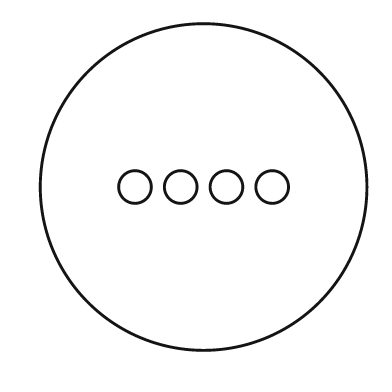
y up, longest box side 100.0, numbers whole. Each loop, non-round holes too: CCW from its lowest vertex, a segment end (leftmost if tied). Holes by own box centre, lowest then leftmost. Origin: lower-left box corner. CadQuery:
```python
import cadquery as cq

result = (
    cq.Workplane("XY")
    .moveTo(50.0, 50.0)
    .circle(50.0)
    .moveTo(29.0, 50.0)
    .circle(5.0)
    .moveTo(43.0, 50.0)
    .circle(5.0)
    .moveTo(57.0, 50.0)
    .circle(5.0)
    .moveTo(71.0, 50.0)
    .circle(5.0)
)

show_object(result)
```